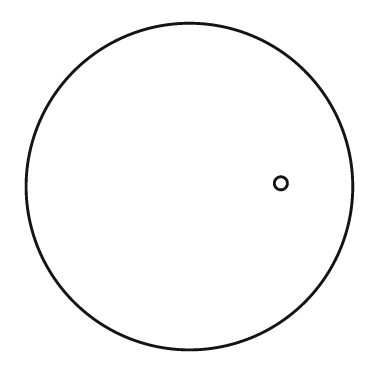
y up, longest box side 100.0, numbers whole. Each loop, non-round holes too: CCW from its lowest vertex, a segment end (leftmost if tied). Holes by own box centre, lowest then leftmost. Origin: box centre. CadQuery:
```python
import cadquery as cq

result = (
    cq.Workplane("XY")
    .moveTo(0.0, 0.0)
    .circle(50.0)
    .moveTo(28.0, 1.0)
    .circle(2.0)
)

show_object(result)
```